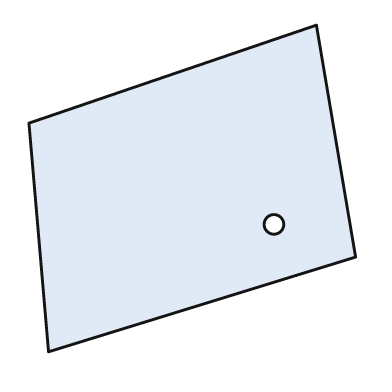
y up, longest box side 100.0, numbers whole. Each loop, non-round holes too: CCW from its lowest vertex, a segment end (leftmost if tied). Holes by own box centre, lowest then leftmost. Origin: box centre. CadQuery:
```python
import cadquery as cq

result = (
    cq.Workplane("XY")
    .moveTo(-44.0, -50.0)
    .lineTo(50.0, -21.0)
    .lineTo(38.0, 50.0)
    .lineTo(-50.0, 20.0)
    .close()
    .moveTo(25.0, -11.0)
    .circle(3.0)
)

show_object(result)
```